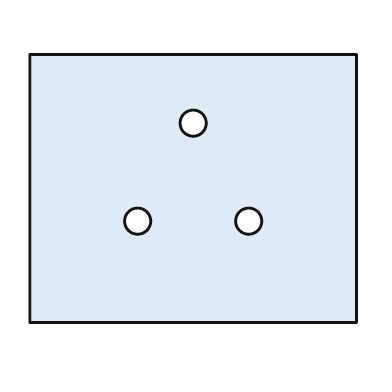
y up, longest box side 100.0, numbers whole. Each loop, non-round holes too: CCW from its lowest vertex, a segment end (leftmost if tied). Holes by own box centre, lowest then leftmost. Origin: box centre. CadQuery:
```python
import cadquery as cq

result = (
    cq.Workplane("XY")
    .moveTo(-50.0, -41.0)
    .lineTo(50.0, -41.0)
    .lineTo(50.0, 41.0)
    .lineTo(-50.0, 41.0)
    .close()
    .moveTo(-17.0, -10.0)
    .circle(4.0)
    .moveTo(17.0, -10.0)
    .circle(4.0)
    .moveTo(0.0, 20.0)
    .circle(4.0)
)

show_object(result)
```